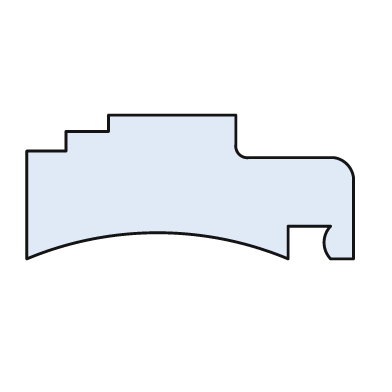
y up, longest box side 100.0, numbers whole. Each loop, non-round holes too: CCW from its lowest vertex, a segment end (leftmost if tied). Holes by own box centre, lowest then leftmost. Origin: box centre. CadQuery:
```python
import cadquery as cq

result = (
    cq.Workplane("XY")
    .moveTo(-50.0, -22.0)
    .threePointArc((-10.0, -14.0), (30.0, -22.0))
    .lineTo(30.0, -12.0)
    .lineTo(43.0, -12.0)
    .threePointArc((41.0, -17.0), (43.0, -22.0))
    .lineTo(50.0, -22.0)
    .lineTo(50.0, 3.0)
    .threePointArc((48.0, 7.0), (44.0, 9.0))
    .lineTo(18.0, 9.0)
    .threePointArc((15.0, 10.0), (14.0, 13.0))
    .lineTo(14.0, 22.0)
    .lineTo(-25.0, 22.0)
    .lineTo(-25.0, 17.0)
    .lineTo(-38.0, 17.0)
    .lineTo(-38.0, 11.0)
    .lineTo(-50.0, 11.0)
    .close()
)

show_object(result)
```